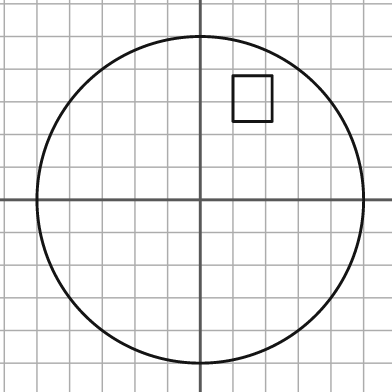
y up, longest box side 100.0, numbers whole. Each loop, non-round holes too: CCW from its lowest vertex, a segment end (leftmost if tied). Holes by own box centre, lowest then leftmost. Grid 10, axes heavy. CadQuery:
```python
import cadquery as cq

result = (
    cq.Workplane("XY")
    .moveTo(0.0, 0.0)
    .circle(50.0)
    .moveTo(10.0, 24.0)
    .lineTo(22.0, 24.0)
    .lineTo(22.0, 38.0)
    .lineTo(10.0, 38.0)
    .close()
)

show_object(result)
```